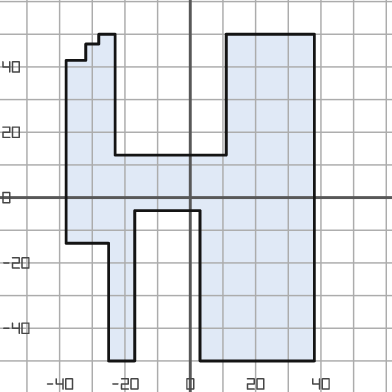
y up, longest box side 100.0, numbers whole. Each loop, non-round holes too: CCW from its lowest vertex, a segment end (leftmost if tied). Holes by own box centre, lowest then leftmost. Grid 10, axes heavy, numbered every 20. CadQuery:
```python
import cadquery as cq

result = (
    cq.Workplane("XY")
    .moveTo(-25.0, -50.0)
    .lineTo(-17.0, -50.0)
    .lineTo(-17.0, -4.0)
    .lineTo(3.0, -4.0)
    .lineTo(3.0, -50.0)
    .lineTo(38.0, -50.0)
    .lineTo(38.0, 50.0)
    .lineTo(11.0, 50.0)
    .lineTo(11.0, 13.0)
    .lineTo(-23.0, 13.0)
    .lineTo(-23.0, 50.0)
    .lineTo(-28.0, 50.0)
    .lineTo(-28.0, 47.0)
    .lineTo(-32.0, 47.0)
    .lineTo(-32.0, 42.0)
    .lineTo(-38.0, 42.0)
    .lineTo(-38.0, -14.0)
    .lineTo(-25.0, -14.0)
    .close()
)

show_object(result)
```